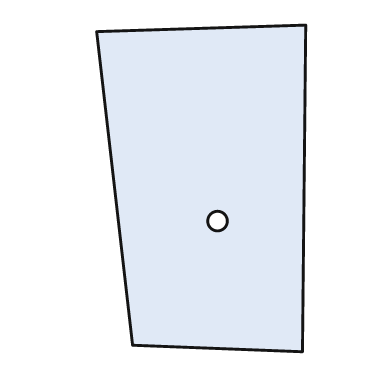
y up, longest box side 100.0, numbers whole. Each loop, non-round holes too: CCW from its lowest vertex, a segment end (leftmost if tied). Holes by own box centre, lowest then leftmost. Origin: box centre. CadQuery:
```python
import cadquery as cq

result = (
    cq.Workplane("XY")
    .moveTo(31.0, -50.0)
    .lineTo(32.0, 50.0)
    .lineTo(-32.0, 48.0)
    .lineTo(-21.0, -48.0)
    .close()
    .moveTo(5.0, -10.0)
    .circle(3.0)
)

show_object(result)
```